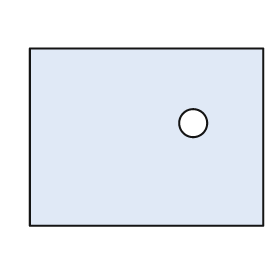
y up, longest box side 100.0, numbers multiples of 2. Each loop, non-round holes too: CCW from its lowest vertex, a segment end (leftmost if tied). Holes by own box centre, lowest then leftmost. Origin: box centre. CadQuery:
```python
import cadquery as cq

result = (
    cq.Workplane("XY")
    .moveTo(-50.0, -38.0)
    .lineTo(50.0, -38.0)
    .lineTo(50.0, 38.0)
    .lineTo(-50.0, 38.0)
    .close()
    .moveTo(20.0, 6.0)
    .circle(6.0)
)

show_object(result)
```